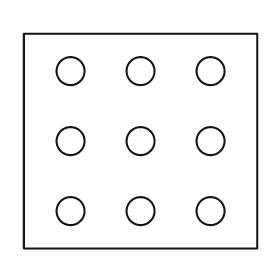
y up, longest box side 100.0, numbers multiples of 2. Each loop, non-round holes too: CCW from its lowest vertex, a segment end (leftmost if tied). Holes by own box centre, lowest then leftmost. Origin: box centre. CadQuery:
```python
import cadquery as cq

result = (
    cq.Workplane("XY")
    .moveTo(-50.0, -46.0)
    .lineTo(50.0, -46.0)
    .lineTo(50.0, 46.0)
    .lineTo(-50.0, 46.0)
    .close()
    .moveTo(-30.0, -30.0)
    .circle(6.0)
    .moveTo(0.0, -30.0)
    .circle(6.0)
    .moveTo(30.0, -30.0)
    .circle(6.0)
    .moveTo(-30.0, 0.0)
    .circle(6.0)
    .moveTo(0.0, 0.0)
    .circle(6.0)
    .moveTo(30.0, 0.0)
    .circle(6.0)
    .moveTo(-30.0, 30.0)
    .circle(6.0)
    .moveTo(0.0, 30.0)
    .circle(6.0)
    .moveTo(30.0, 30.0)
    .circle(6.0)
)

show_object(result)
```